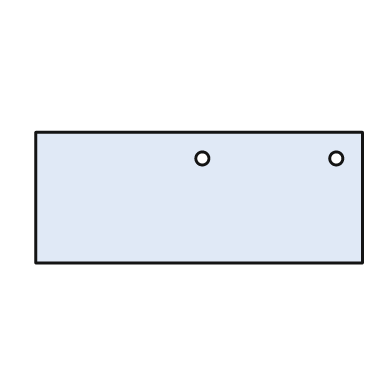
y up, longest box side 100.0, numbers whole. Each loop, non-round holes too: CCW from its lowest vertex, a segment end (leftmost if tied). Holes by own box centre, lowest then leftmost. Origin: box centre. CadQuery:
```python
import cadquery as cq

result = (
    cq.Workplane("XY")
    .moveTo(-50.0, -20.0)
    .lineTo(50.0, -20.0)
    .lineTo(50.0, 20.0)
    .lineTo(-50.0, 20.0)
    .close()
    .moveTo(1.0, 12.0)
    .circle(2.0)
    .moveTo(42.0, 12.0)
    .circle(2.0)
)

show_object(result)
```